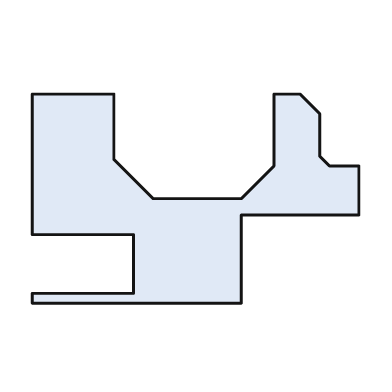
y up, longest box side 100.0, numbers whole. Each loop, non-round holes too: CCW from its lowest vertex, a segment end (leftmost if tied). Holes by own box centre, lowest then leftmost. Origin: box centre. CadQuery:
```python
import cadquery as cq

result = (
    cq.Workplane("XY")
    .moveTo(-50.0, -32.0)
    .lineTo(14.0, -32.0)
    .lineTo(14.0, -5.0)
    .lineTo(50.0, -5.0)
    .lineTo(50.0, 10.0)
    .lineTo(41.0, 10.0)
    .lineTo(38.0, 13.0)
    .lineTo(38.0, 26.0)
    .lineTo(32.0, 32.0)
    .lineTo(24.0, 32.0)
    .lineTo(24.0, 10.0)
    .lineTo(14.0, 0.0)
    .lineTo(-13.0, 0.0)
    .lineTo(-25.0, 12.0)
    .lineTo(-25.0, 32.0)
    .lineTo(-50.0, 32.0)
    .lineTo(-50.0, -11.0)
    .lineTo(-19.0, -11.0)
    .lineTo(-19.0, -29.0)
    .lineTo(-50.0, -29.0)
    .close()
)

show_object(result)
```